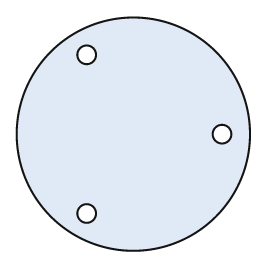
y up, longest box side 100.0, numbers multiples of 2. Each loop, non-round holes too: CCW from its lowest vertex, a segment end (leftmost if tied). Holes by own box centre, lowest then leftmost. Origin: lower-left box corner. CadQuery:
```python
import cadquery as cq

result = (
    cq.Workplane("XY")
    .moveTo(50.0, 50.0)
    .circle(50.0)
    .moveTo(30.0, 16.0)
    .circle(4.0)
    .moveTo(88.0, 50.0)
    .circle(4.0)
    .moveTo(30.0, 84.0)
    .circle(4.0)
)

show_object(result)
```